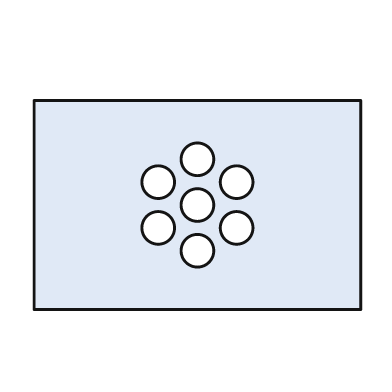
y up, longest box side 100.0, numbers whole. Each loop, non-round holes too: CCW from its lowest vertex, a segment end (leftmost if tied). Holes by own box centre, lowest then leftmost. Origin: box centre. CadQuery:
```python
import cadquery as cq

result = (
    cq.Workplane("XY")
    .moveTo(-50.0, -32.0)
    .lineTo(50.0, -32.0)
    .lineTo(50.0, 32.0)
    .lineTo(-50.0, 32.0)
    .close()
    .moveTo(0.0, -14.0)
    .circle(5.0)
    .moveTo(-12.0, -7.0)
    .circle(5.0)
    .moveTo(12.0, -7.0)
    .circle(5.0)
    .moveTo(0.0, 0.0)
    .circle(5.0)
    .moveTo(-12.0, 7.0)
    .circle(5.0)
    .moveTo(12.0, 7.0)
    .circle(5.0)
    .moveTo(0.0, 14.0)
    .circle(5.0)
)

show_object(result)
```